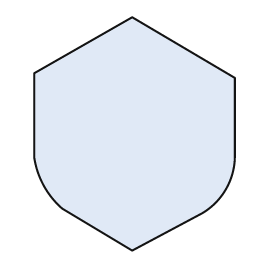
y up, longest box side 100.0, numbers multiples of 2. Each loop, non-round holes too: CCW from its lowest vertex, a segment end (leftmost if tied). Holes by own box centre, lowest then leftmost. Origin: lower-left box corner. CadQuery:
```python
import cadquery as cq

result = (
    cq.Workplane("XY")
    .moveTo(42.0, 0.0)
    .lineTo(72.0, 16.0)
    .threePointArc((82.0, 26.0), (86.0, 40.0))
    .lineTo(86.0, 74.0)
    .lineTo(42.0, 100.0)
    .lineTo(0.0, 76.0)
    .lineTo(0.0, 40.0)
    .threePointArc((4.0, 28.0), (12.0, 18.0))
    .close()
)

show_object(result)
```